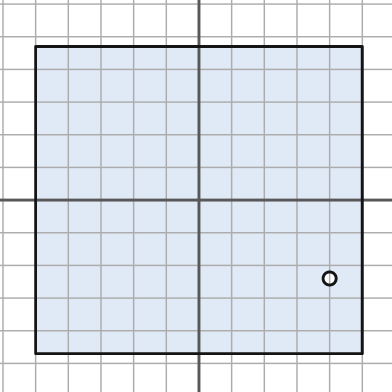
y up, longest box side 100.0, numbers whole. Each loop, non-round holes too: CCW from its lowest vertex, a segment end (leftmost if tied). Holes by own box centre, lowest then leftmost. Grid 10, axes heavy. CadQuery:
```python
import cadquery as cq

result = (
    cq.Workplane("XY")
    .moveTo(-50.0, -47.0)
    .lineTo(50.0, -47.0)
    .lineTo(50.0, 47.0)
    .lineTo(-50.0, 47.0)
    .close()
    .moveTo(40.0, -24.0)
    .circle(2.0)
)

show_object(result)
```